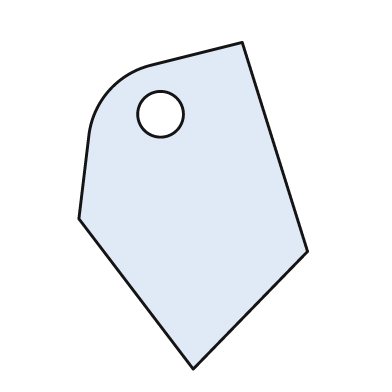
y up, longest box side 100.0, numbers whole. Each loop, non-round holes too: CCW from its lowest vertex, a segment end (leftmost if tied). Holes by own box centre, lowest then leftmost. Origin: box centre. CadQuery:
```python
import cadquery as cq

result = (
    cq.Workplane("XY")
    .moveTo(0.0, -50.0)
    .lineTo(35.0, -14.0)
    .lineTo(15.0, 50.0)
    .lineTo(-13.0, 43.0)
    .threePointArc((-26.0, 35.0), (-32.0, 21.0))
    .lineTo(-35.0, -4.0)
    .close()
    .moveTo(-10.0, 28.0)
    .circle(7.0)
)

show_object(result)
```